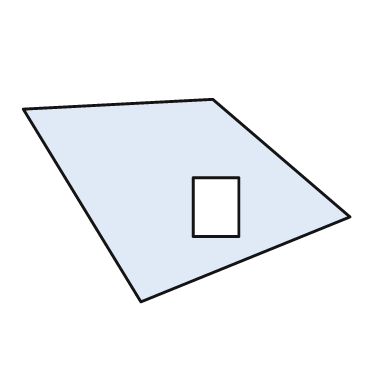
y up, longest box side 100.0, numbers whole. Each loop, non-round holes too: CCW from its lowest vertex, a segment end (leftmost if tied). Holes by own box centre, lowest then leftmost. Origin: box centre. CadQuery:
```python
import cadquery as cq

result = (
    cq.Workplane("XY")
    .moveTo(-14.0, -31.0)
    .lineTo(50.0, -5.0)
    .lineTo(8.0, 31.0)
    .lineTo(-50.0, 28.0)
    .close()
    .moveTo(2.0, -11.0)
    .lineTo(16.0, -11.0)
    .lineTo(16.0, 7.0)
    .lineTo(2.0, 7.0)
    .close()
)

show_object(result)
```